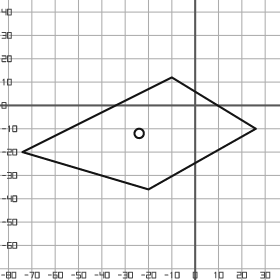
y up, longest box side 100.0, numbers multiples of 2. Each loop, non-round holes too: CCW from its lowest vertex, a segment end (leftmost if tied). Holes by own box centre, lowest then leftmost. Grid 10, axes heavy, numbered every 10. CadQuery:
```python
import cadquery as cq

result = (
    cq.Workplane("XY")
    .moveTo(-20.0, -36.0)
    .lineTo(26.0, -10.0)
    .lineTo(-10.0, 12.0)
    .lineTo(-74.0, -20.0)
    .close()
    .moveTo(-24.0, -12.0)
    .circle(2.0)
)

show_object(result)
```